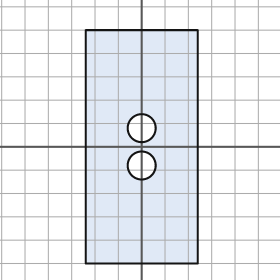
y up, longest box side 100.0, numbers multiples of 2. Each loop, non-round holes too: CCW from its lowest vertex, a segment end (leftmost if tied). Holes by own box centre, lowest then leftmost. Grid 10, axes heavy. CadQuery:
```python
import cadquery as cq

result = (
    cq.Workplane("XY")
    .moveTo(-24.0, -50.0)
    .lineTo(24.0, -50.0)
    .lineTo(24.0, 50.0)
    .lineTo(-24.0, 50.0)
    .close()
    .moveTo(0.0, -8.0)
    .circle(6.0)
    .moveTo(0.0, 8.0)
    .circle(6.0)
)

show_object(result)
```